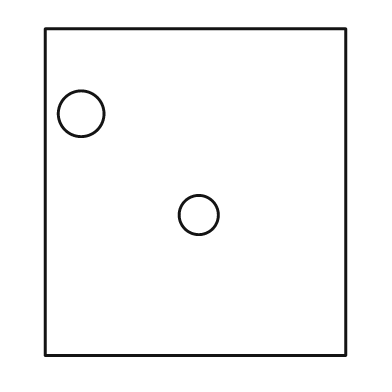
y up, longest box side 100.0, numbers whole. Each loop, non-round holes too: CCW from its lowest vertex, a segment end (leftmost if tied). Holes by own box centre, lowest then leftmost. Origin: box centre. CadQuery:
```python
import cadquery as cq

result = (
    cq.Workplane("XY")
    .moveTo(-46.0, -50.0)
    .lineTo(46.0, -50.0)
    .lineTo(46.0, 50.0)
    .lineTo(-46.0, 50.0)
    .close()
    .moveTo(1.0, -7.0)
    .circle(6.0)
    .moveTo(-35.0, 24.0)
    .circle(7.0)
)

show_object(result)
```